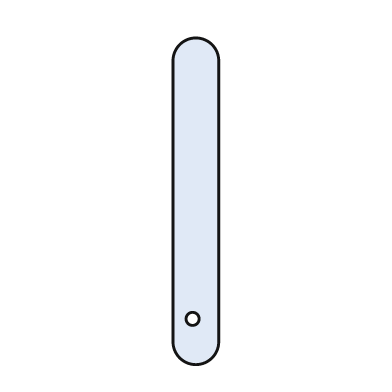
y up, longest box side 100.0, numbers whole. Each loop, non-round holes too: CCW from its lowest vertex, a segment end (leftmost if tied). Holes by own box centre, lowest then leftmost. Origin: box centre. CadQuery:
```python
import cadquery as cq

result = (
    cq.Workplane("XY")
    .moveTo(-7.0, -43.0)
    .threePointArc((0.0, -50.0), (7.0, -43.0))
    .lineTo(7.0, 43.0)
    .threePointArc((0.0, 50.0), (-7.0, 43.0))
    .close()
    .moveTo(-1.0, -36.0)
    .circle(2.0)
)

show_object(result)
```